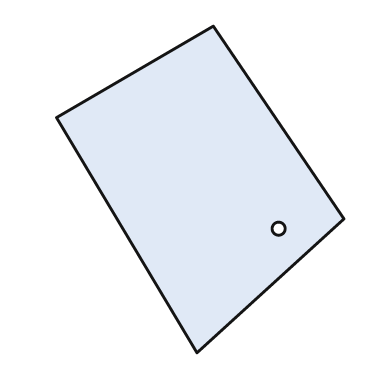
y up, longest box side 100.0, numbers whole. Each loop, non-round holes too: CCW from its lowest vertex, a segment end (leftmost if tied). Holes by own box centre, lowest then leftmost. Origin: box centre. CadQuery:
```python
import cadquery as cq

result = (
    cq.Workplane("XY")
    .moveTo(-1.0, -50.0)
    .lineTo(44.0, -9.0)
    .lineTo(4.0, 50.0)
    .lineTo(-44.0, 22.0)
    .close()
    .moveTo(24.0, -12.0)
    .circle(2.0)
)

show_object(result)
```